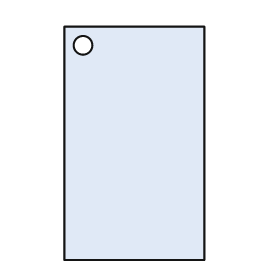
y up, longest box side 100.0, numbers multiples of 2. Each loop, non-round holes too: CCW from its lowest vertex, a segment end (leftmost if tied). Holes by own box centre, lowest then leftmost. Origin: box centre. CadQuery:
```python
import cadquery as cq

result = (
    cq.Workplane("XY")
    .moveTo(-30.0, -50.0)
    .lineTo(30.0, -50.0)
    .lineTo(30.0, 50.0)
    .lineTo(-30.0, 50.0)
    .close()
    .moveTo(-22.0, 42.0)
    .circle(4.0)
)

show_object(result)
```